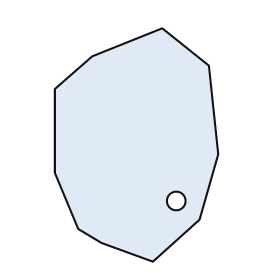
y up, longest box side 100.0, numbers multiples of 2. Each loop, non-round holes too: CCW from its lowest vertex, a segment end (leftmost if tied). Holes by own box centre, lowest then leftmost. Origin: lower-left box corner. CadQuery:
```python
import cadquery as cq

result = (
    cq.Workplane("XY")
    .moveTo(42.0, 0.0)
    .lineTo(62.0, 18.0)
    .lineTo(70.0, 46.0)
    .lineTo(66.0, 84.0)
    .lineTo(46.0, 100.0)
    .lineTo(16.0, 88.0)
    .lineTo(0.0, 74.0)
    .lineTo(0.0, 38.0)
    .lineTo(10.0, 14.0)
    .lineTo(20.0, 8.0)
    .close()
    .moveTo(52.0, 26.0)
    .circle(4.0)
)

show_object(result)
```